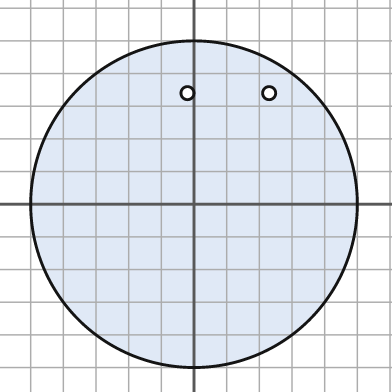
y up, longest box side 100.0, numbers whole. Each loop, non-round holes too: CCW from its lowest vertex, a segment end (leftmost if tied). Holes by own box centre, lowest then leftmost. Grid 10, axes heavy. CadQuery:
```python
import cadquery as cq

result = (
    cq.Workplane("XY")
    .moveTo(0.0, 0.0)
    .circle(50.0)
    .moveTo(-2.0, 34.0)
    .circle(2.0)
    .moveTo(23.0, 34.0)
    .circle(2.0)
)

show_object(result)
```